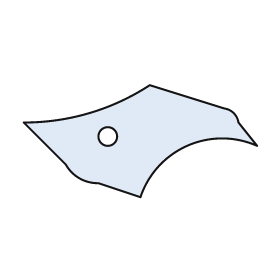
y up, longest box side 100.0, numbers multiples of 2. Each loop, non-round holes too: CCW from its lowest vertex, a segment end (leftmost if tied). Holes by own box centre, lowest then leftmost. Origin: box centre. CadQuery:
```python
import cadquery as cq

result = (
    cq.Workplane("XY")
    .moveTo(0.0, -24.0)
    .threePointArc((20.0, -2.0), (50.0, -2.0))
    .lineTo(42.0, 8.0)
    .threePointArc((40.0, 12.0), (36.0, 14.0))
    .lineTo(4.0, 24.0)
    .threePointArc((-22.0, 12.0), (-50.0, 8.0))
    .lineTo(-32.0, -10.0)
    .threePointArc((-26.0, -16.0), (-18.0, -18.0))
    .close()
    .moveTo(-14.0, 2.0)
    .circle(4.0)
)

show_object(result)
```